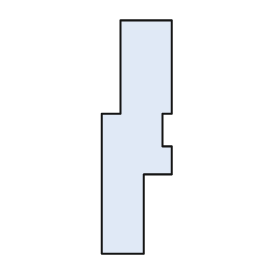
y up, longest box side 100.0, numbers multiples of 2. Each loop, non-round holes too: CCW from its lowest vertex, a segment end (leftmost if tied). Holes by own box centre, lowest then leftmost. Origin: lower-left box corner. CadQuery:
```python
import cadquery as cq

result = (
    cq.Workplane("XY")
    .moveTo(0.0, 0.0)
    .lineTo(18.0, 0.0)
    .lineTo(18.0, 34.0)
    .lineTo(30.0, 34.0)
    .lineTo(30.0, 46.0)
    .lineTo(26.0, 46.0)
    .lineTo(26.0, 60.0)
    .lineTo(30.0, 60.0)
    .lineTo(30.0, 100.0)
    .lineTo(8.0, 100.0)
    .lineTo(8.0, 60.0)
    .lineTo(0.0, 60.0)
    .close()
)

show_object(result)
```